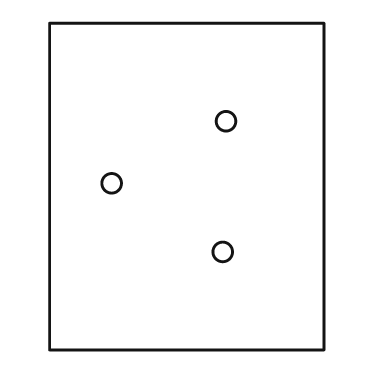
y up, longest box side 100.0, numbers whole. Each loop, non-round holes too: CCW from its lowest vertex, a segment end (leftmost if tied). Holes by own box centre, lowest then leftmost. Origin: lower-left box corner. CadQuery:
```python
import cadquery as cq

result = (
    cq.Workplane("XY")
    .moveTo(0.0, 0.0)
    .lineTo(84.0, 0.0)
    .lineTo(84.0, 100.0)
    .lineTo(0.0, 100.0)
    .close()
    .moveTo(53.0, 30.0)
    .circle(3.0)
    .moveTo(19.0, 51.0)
    .circle(3.0)
    .moveTo(54.0, 70.0)
    .circle(3.0)
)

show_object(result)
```